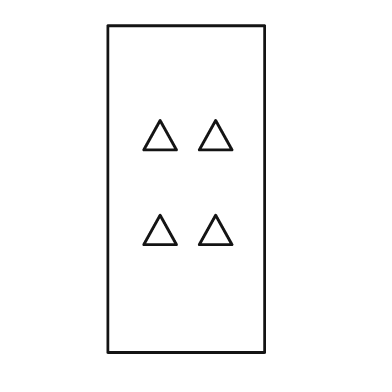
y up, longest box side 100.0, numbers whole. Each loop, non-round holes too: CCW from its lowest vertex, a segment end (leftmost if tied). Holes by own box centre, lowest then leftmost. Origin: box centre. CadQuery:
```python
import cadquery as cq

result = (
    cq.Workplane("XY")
    .moveTo(-24.0, -50.0)
    .lineTo(24.0, -50.0)
    .lineTo(24.0, 50.0)
    .lineTo(-24.0, 50.0)
    .close()
    .moveTo(-13.0, -17.0)
    .lineTo(-3.0, -17.0)
    .lineTo(-8.0, -8.0)
    .close()
    .moveTo(4.0, -17.0)
    .lineTo(14.0, -17.0)
    .lineTo(9.0, -8.0)
    .close()
    .moveTo(-13.0, 12.0)
    .lineTo(-3.0, 12.0)
    .lineTo(-8.0, 21.0)
    .close()
    .moveTo(4.0, 12.0)
    .lineTo(14.0, 12.0)
    .lineTo(9.0, 21.0)
    .close()
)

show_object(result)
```